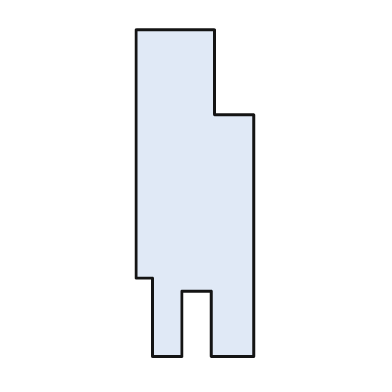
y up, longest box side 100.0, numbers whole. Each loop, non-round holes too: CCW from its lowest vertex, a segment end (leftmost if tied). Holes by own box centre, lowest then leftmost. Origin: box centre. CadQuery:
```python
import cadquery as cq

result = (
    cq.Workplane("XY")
    .moveTo(-13.0, -50.0)
    .lineTo(-4.0, -50.0)
    .lineTo(-4.0, -30.0)
    .lineTo(5.0, -30.0)
    .lineTo(5.0, -50.0)
    .lineTo(18.0, -50.0)
    .lineTo(18.0, 24.0)
    .lineTo(6.0, 24.0)
    .lineTo(6.0, 50.0)
    .lineTo(-18.0, 50.0)
    .lineTo(-18.0, -26.0)
    .lineTo(-13.0, -26.0)
    .close()
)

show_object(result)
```